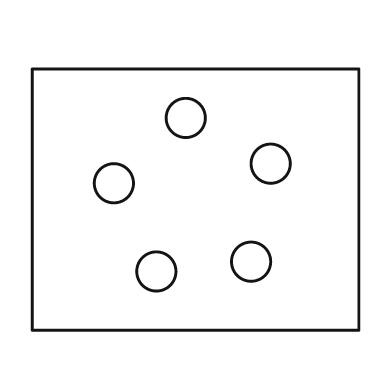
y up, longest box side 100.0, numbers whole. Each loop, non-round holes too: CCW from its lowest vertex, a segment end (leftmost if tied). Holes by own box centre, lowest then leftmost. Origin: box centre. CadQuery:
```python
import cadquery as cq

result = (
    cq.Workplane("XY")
    .moveTo(-50.0, -40.0)
    .lineTo(50.0, -40.0)
    .lineTo(50.0, 40.0)
    .lineTo(-50.0, 40.0)
    .close()
    .moveTo(-12.0, -22.0)
    .circle(6.0)
    .moveTo(17.0, -19.0)
    .circle(6.0)
    .moveTo(-25.0, 5.0)
    .circle(6.0)
    .moveTo(23.0, 11.0)
    .circle(6.0)
    .moveTo(-3.0, 25.0)
    .circle(6.0)
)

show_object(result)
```